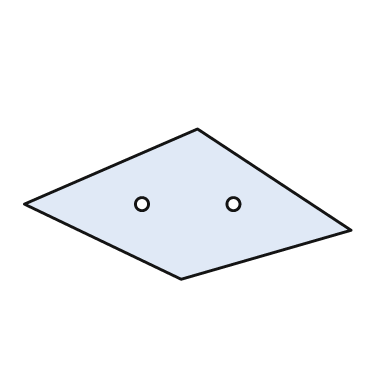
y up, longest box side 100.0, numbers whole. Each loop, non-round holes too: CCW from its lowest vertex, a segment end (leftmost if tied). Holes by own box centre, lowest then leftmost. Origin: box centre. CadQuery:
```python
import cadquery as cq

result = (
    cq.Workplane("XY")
    .moveTo(-2.0, -23.0)
    .lineTo(50.0, -8.0)
    .lineTo(3.0, 23.0)
    .lineTo(-50.0, 0.0)
    .close()
    .moveTo(-14.0, 0.0)
    .circle(2.0)
    .moveTo(14.0, 0.0)
    .circle(2.0)
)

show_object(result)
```